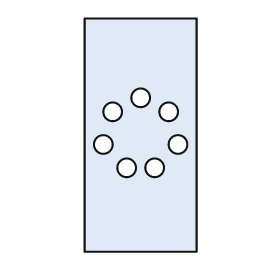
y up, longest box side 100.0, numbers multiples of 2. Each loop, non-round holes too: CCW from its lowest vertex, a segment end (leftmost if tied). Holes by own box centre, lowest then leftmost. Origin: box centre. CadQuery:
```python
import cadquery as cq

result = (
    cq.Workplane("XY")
    .moveTo(-24.0, -50.0)
    .lineTo(24.0, -50.0)
    .lineTo(24.0, 50.0)
    .lineTo(-24.0, 50.0)
    .close()
    .moveTo(-6.0, -14.0)
    .circle(4.0)
    .moveTo(6.0, -14.0)
    .circle(4.0)
    .moveTo(-16.0, -4.0)
    .circle(4.0)
    .moveTo(16.0, -4.0)
    .circle(4.0)
    .moveTo(-12.0, 10.0)
    .circle(4.0)
    .moveTo(12.0, 10.0)
    .circle(4.0)
    .moveTo(0.0, 16.0)
    .circle(4.0)
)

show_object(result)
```